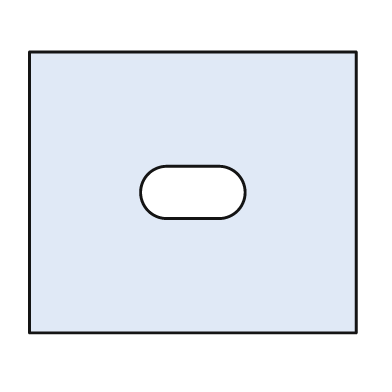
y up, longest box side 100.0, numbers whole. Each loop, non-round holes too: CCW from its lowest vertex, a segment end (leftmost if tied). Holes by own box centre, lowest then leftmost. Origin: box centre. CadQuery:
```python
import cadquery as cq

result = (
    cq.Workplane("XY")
    .moveTo(-50.0, -43.0)
    .lineTo(50.0, -43.0)
    .lineTo(50.0, 43.0)
    .lineTo(-50.0, 43.0)
    .close()
    .moveTo(-8.0, -8.0)
    .lineTo(8.0, -8.0)
    .threePointArc((16.0, 0.0), (8.0, 8.0))
    .lineTo(-8.0, 8.0)
    .threePointArc((-16.0, 0.0), (-8.0, -8.0))
    .close()
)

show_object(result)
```